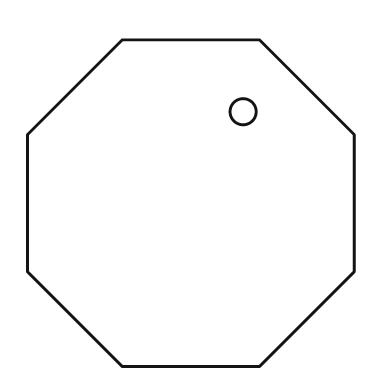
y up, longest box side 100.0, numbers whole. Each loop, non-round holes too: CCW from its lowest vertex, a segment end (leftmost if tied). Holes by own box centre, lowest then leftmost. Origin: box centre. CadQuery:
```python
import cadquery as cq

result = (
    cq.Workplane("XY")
    .moveTo(-21.0, -50.0)
    .lineTo(21.0, -50.0)
    .lineTo(50.0, -21.0)
    .lineTo(50.0, 21.0)
    .lineTo(21.0, 50.0)
    .lineTo(-21.0, 50.0)
    .lineTo(-50.0, 21.0)
    .lineTo(-50.0, -21.0)
    .close()
    .moveTo(16.0, 28.0)
    .circle(4.0)
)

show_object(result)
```